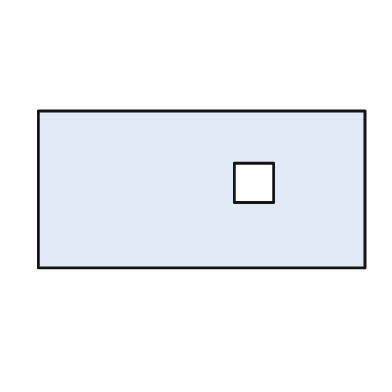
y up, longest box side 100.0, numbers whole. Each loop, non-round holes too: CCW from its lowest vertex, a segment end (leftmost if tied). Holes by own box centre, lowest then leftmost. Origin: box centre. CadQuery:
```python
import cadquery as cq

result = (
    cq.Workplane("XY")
    .moveTo(-50.0, -24.0)
    .lineTo(50.0, -24.0)
    .lineTo(50.0, 24.0)
    .lineTo(-50.0, 24.0)
    .close()
    .moveTo(10.0, -4.0)
    .lineTo(22.0, -4.0)
    .lineTo(22.0, 8.0)
    .lineTo(10.0, 8.0)
    .close()
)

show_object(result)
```